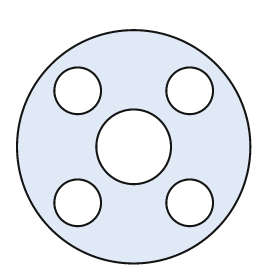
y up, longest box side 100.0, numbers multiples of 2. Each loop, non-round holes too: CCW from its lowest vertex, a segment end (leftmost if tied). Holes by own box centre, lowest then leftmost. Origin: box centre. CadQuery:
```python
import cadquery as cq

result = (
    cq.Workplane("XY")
    .moveTo(0.0, 0.0)
    .circle(50.0)
    .moveTo(-24.0, -24.0)
    .circle(10.0)
    .moveTo(24.0, -24.0)
    .circle(10.0)
    .moveTo(0.0, 0.0)
    .circle(16.0)
    .moveTo(-24.0, 24.0)
    .circle(10.0)
    .moveTo(24.0, 24.0)
    .circle(10.0)
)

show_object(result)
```